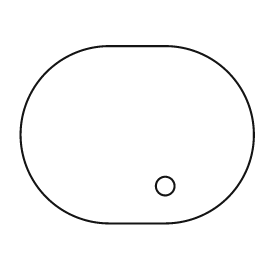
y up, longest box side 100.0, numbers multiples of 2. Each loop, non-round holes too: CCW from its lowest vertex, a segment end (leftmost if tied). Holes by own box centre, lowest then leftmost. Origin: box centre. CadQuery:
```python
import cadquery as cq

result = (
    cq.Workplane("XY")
    .moveTo(-12.0, -38.0)
    .lineTo(12.0, -38.0)
    .threePointArc((50.0, 0.0), (12.0, 38.0))
    .lineTo(-12.0, 38.0)
    .threePointArc((-50.0, 0.0), (-12.0, -38.0))
    .close()
    .moveTo(12.0, -22.0)
    .circle(4.0)
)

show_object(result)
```